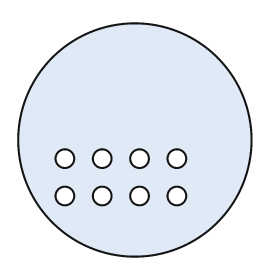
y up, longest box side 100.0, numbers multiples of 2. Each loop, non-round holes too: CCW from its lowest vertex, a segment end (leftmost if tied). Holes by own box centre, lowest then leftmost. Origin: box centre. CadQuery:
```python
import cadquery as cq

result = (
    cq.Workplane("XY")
    .moveTo(0.0, 0.0)
    .circle(50.0)
    .moveTo(-30.0, -24.0)
    .circle(4.0)
    .moveTo(-14.0, -24.0)
    .circle(4.0)
    .moveTo(2.0, -24.0)
    .circle(4.0)
    .moveTo(18.0, -24.0)
    .circle(4.0)
    .moveTo(-30.0, -8.0)
    .circle(4.0)
    .moveTo(-14.0, -8.0)
    .circle(4.0)
    .moveTo(2.0, -8.0)
    .circle(4.0)
    .moveTo(18.0, -8.0)
    .circle(4.0)
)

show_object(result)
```